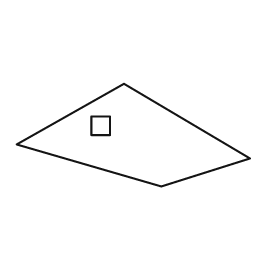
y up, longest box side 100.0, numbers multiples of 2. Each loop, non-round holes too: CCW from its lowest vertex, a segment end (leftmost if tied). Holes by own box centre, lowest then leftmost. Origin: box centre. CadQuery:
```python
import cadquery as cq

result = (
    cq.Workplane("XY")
    .moveTo(12.0, -22.0)
    .lineTo(50.0, -10.0)
    .lineTo(-4.0, 22.0)
    .lineTo(-50.0, -4.0)
    .close()
    .moveTo(-18.0, 0.0)
    .lineTo(-10.0, 0.0)
    .lineTo(-10.0, 8.0)
    .lineTo(-18.0, 8.0)
    .close()
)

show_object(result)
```